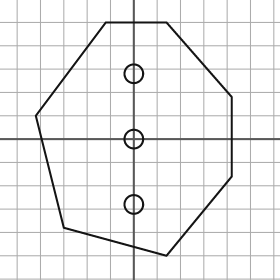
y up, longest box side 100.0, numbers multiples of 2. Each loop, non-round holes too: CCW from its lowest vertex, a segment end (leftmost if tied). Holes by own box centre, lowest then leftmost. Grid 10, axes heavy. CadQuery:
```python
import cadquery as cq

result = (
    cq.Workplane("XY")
    .moveTo(14.0, -50.0)
    .lineTo(42.0, -16.0)
    .lineTo(42.0, 18.0)
    .lineTo(14.0, 50.0)
    .lineTo(-12.0, 50.0)
    .lineTo(-42.0, 10.0)
    .lineTo(-30.0, -38.0)
    .close()
    .moveTo(0.0, -28.0)
    .circle(4.0)
    .moveTo(0.0, 0.0)
    .circle(4.0)
    .moveTo(0.0, 28.0)
    .circle(4.0)
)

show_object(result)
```